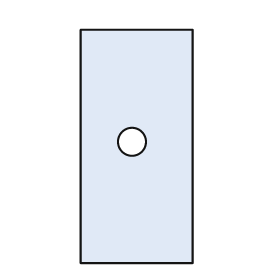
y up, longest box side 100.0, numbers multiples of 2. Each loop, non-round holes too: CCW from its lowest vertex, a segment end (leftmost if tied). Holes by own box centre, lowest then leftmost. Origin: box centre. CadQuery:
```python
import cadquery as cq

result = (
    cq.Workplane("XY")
    .moveTo(-24.0, -50.0)
    .lineTo(24.0, -50.0)
    .lineTo(24.0, 50.0)
    .lineTo(-24.0, 50.0)
    .close()
    .moveTo(-2.0, 2.0)
    .circle(6.0)
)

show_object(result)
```